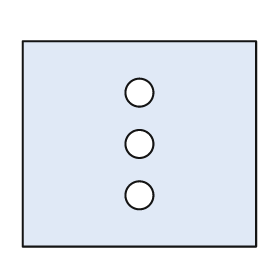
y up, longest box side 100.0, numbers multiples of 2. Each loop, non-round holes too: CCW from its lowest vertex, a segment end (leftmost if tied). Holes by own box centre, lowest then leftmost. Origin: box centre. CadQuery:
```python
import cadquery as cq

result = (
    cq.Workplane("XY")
    .moveTo(-50.0, -44.0)
    .lineTo(50.0, -44.0)
    .lineTo(50.0, 44.0)
    .lineTo(-50.0, 44.0)
    .close()
    .moveTo(0.0, -22.0)
    .circle(6.0)
    .moveTo(0.0, 0.0)
    .circle(6.0)
    .moveTo(0.0, 22.0)
    .circle(6.0)
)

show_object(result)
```